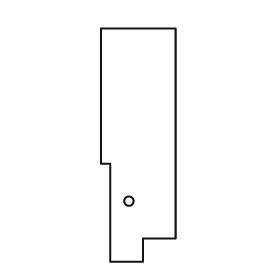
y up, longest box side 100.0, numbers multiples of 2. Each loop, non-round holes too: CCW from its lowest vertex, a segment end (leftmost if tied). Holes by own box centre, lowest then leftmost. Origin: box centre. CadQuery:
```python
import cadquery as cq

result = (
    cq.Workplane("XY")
    .moveTo(-12.0, -50.0)
    .lineTo(2.0, -50.0)
    .lineTo(2.0, -40.0)
    .lineTo(16.0, -40.0)
    .lineTo(16.0, 50.0)
    .lineTo(-16.0, 50.0)
    .lineTo(-16.0, -8.0)
    .lineTo(-12.0, -8.0)
    .close()
    .moveTo(-4.0, -24.0)
    .circle(2.0)
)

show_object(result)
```